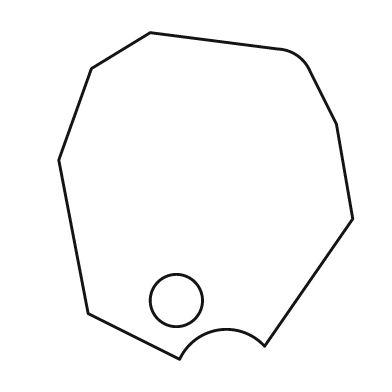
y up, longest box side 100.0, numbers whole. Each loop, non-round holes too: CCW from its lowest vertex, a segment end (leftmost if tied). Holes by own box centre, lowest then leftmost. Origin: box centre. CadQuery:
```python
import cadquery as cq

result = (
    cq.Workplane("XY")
    .moveTo(-8.0, -50.0)
    .threePointArc((4.0, -41.0), (18.0, -46.0))
    .lineTo(45.0, -7.0)
    .lineTo(40.0, 22.0)
    .lineTo(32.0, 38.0)
    .threePointArc((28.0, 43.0), (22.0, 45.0))
    .lineTo(-17.0, 50.0)
    .lineTo(-35.0, 39.0)
    .lineTo(-45.0, 11.0)
    .lineTo(-36.0, -36.0)
    .close()
    .moveTo(-9.0, -32.0)
    .circle(8.0)
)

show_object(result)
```